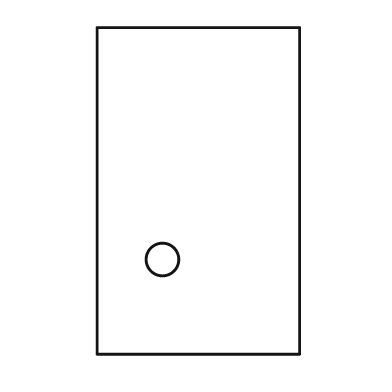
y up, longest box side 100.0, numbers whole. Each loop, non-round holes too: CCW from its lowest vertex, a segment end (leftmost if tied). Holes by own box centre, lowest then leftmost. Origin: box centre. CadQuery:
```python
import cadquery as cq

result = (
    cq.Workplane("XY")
    .moveTo(-31.0, -50.0)
    .lineTo(31.0, -50.0)
    .lineTo(31.0, 50.0)
    .lineTo(-31.0, 50.0)
    .close()
    .moveTo(-11.0, -21.0)
    .circle(5.0)
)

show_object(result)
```